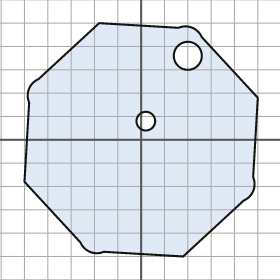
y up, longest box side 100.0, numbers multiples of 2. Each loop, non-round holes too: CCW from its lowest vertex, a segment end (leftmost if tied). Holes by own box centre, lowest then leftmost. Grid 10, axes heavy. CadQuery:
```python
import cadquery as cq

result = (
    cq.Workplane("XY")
    .moveTo(18.0, -50.0)
    .lineTo(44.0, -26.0)
    .threePointArc((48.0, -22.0), (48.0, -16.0))
    .lineTo(50.0, 18.0)
    .lineTo(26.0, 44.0)
    .threePointArc((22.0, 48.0), (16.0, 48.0))
    .lineTo(-18.0, 50.0)
    .lineTo(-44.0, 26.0)
    .threePointArc((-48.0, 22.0), (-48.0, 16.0))
    .lineTo(-50.0, -18.0)
    .lineTo(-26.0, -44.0)
    .threePointArc((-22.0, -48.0), (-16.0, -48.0))
    .close()
    .moveTo(2.0, 8.0)
    .circle(4.0)
    .moveTo(20.0, 36.0)
    .circle(6.0)
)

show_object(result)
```